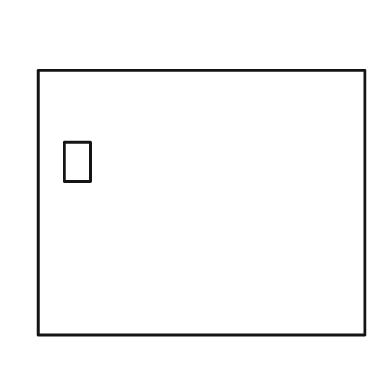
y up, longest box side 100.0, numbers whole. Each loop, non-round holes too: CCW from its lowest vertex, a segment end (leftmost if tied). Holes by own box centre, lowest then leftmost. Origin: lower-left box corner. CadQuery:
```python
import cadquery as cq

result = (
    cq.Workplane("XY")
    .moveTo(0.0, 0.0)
    .lineTo(100.0, 0.0)
    .lineTo(100.0, 81.0)
    .lineTo(0.0, 81.0)
    .close()
    .moveTo(8.0, 47.0)
    .lineTo(16.0, 47.0)
    .lineTo(16.0, 59.0)
    .lineTo(8.0, 59.0)
    .close()
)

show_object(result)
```